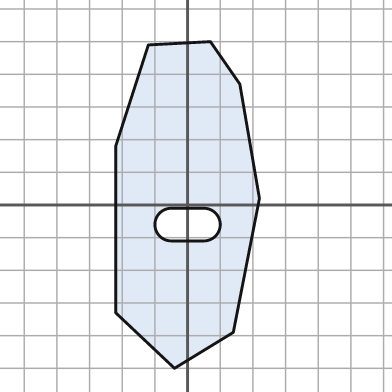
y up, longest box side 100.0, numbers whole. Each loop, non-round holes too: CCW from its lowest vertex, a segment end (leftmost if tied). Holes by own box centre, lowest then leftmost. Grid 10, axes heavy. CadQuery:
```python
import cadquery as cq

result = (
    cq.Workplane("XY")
    .moveTo(-4.0, -50.0)
    .lineTo(14.0, -39.0)
    .lineTo(22.0, 2.0)
    .lineTo(16.0, 37.0)
    .lineTo(7.0, 50.0)
    .lineTo(-12.0, 49.0)
    .lineTo(-22.0, 18.0)
    .lineTo(-22.0, -33.0)
    .close()
    .moveTo(-5.0, -11.0)
    .lineTo(5.0, -11.0)
    .threePointArc((10.0, -6.0), (5.0, -1.0))
    .lineTo(-5.0, -1.0)
    .threePointArc((-10.0, -6.0), (-5.0, -11.0))
    .close()
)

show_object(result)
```